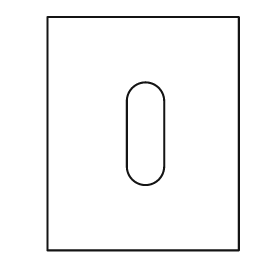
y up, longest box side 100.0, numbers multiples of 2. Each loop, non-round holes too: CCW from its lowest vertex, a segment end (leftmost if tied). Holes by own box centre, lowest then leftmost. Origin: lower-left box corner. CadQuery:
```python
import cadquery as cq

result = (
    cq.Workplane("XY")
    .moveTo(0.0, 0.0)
    .lineTo(82.0, 0.0)
    .lineTo(82.0, 100.0)
    .lineTo(0.0, 100.0)
    .close()
    .moveTo(34.0, 36.0)
    .threePointArc((42.0, 28.0), (50.0, 36.0))
    .lineTo(50.0, 64.0)
    .threePointArc((42.0, 72.0), (34.0, 64.0))
    .close()
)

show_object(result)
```